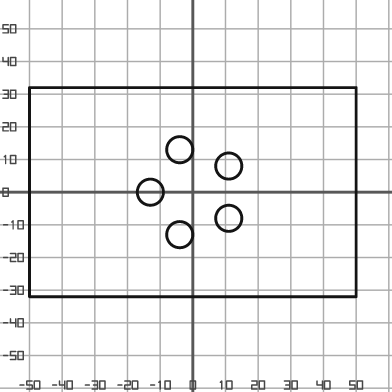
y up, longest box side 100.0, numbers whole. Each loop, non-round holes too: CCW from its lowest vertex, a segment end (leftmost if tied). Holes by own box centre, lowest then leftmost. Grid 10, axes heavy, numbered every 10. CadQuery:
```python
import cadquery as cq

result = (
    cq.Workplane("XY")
    .moveTo(-50.0, -32.0)
    .lineTo(50.0, -32.0)
    .lineTo(50.0, 32.0)
    .lineTo(-50.0, 32.0)
    .close()
    .moveTo(-4.0, -13.0)
    .circle(4.0)
    .moveTo(11.0, -8.0)
    .circle(4.0)
    .moveTo(-13.0, 0.0)
    .circle(4.0)
    .moveTo(11.0, 8.0)
    .circle(4.0)
    .moveTo(-4.0, 13.0)
    .circle(4.0)
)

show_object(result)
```